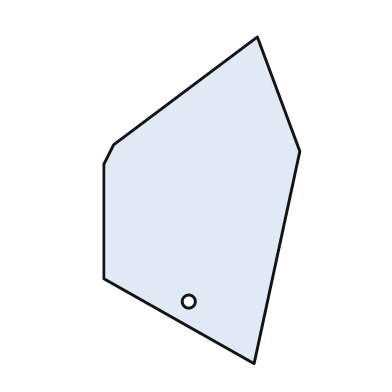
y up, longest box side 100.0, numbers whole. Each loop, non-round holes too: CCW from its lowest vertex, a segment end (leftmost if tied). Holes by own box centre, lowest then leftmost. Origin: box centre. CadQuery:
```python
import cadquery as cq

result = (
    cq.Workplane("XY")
    .moveTo(16.0, -50.0)
    .lineTo(30.0, 15.0)
    .lineTo(17.0, 50.0)
    .lineTo(-27.0, 17.0)
    .lineTo(-30.0, 11.0)
    .lineTo(-30.0, -24.0)
    .close()
    .moveTo(-4.0, -31.0)
    .circle(2.0)
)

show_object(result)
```